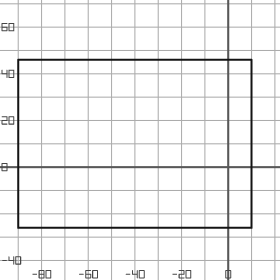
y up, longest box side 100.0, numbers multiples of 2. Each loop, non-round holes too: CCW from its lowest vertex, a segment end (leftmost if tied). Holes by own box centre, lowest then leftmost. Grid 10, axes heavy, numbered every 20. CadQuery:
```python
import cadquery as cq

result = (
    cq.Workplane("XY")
    .moveTo(-90.0, -26.0)
    .lineTo(10.0, -26.0)
    .lineTo(10.0, 46.0)
    .lineTo(-90.0, 46.0)
    .close()
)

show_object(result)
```